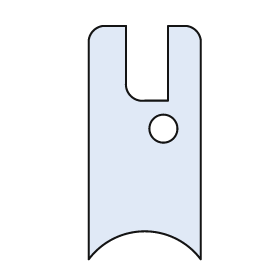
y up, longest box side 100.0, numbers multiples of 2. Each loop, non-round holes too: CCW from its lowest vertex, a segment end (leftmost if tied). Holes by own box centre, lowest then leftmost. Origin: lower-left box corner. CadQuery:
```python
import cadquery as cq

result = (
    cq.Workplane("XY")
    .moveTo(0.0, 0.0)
    .threePointArc((24.0, 12.0), (48.0, 0.0))
    .lineTo(48.0, 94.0)
    .threePointArc((46.0, 98.0), (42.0, 100.0))
    .lineTo(34.0, 100.0)
    .lineTo(34.0, 68.0)
    .lineTo(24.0, 68.0)
    .threePointArc((18.0, 70.0), (16.0, 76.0))
    .lineTo(16.0, 100.0)
    .lineTo(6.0, 100.0)
    .threePointArc((2.0, 98.0), (0.0, 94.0))
    .close()
    .moveTo(32.0, 56.0)
    .circle(6.0)
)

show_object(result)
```